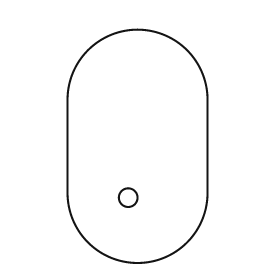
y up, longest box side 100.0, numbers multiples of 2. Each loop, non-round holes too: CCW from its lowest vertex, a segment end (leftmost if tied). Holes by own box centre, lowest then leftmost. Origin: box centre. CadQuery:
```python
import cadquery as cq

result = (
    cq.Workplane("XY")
    .moveTo(-30.0, -20.0)
    .threePointArc((0.0, -50.0), (30.0, -20.0))
    .lineTo(30.0, 20.0)
    .threePointArc((0.0, 50.0), (-30.0, 20.0))
    .close()
    .moveTo(-4.0, -22.0)
    .circle(4.0)
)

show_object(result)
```